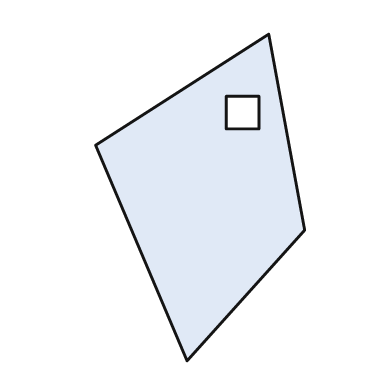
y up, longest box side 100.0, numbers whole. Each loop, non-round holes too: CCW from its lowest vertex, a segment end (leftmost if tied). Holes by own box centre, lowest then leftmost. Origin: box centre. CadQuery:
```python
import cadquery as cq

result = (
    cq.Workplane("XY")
    .moveTo(-4.0, -50.0)
    .lineTo(32.0, -10.0)
    .lineTo(21.0, 50.0)
    .lineTo(-32.0, 16.0)
    .close()
    .moveTo(8.0, 21.0)
    .lineTo(18.0, 21.0)
    .lineTo(18.0, 31.0)
    .lineTo(8.0, 31.0)
    .close()
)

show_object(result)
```